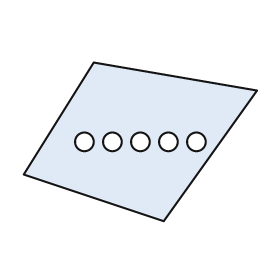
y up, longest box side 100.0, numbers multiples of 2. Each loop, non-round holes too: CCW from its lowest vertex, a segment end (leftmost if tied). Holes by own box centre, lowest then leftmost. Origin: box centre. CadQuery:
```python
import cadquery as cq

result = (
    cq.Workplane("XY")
    .moveTo(10.0, -34.0)
    .lineTo(50.0, 22.0)
    .lineTo(-20.0, 34.0)
    .lineTo(-50.0, -14.0)
    .close()
    .moveTo(-24.0, 0.0)
    .circle(4.0)
    .moveTo(-12.0, 0.0)
    .circle(4.0)
    .moveTo(0.0, 0.0)
    .circle(4.0)
    .moveTo(12.0, 0.0)
    .circle(4.0)
    .moveTo(24.0, 0.0)
    .circle(4.0)
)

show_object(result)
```